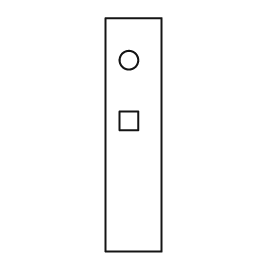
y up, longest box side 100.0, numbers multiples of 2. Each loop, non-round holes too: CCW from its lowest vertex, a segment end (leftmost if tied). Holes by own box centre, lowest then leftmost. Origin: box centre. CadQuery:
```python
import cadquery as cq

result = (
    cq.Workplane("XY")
    .moveTo(-12.0, -50.0)
    .lineTo(12.0, -50.0)
    .lineTo(12.0, 50.0)
    .lineTo(-12.0, 50.0)
    .close()
    .moveTo(-6.0, 2.0)
    .lineTo(2.0, 2.0)
    .lineTo(2.0, 10.0)
    .lineTo(-6.0, 10.0)
    .close()
    .moveTo(-2.0, 32.0)
    .circle(4.0)
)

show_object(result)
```